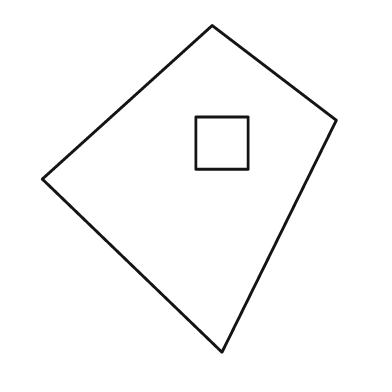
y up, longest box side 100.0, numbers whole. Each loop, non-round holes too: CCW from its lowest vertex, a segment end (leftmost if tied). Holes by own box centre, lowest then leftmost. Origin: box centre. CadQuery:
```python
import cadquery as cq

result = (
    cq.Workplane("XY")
    .moveTo(10.0, -50.0)
    .lineTo(45.0, 21.0)
    .lineTo(7.0, 50.0)
    .lineTo(-45.0, 3.0)
    .close()
    .moveTo(2.0, 6.0)
    .lineTo(18.0, 6.0)
    .lineTo(18.0, 22.0)
    .lineTo(2.0, 22.0)
    .close()
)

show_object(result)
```